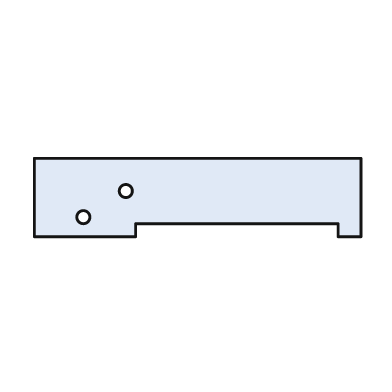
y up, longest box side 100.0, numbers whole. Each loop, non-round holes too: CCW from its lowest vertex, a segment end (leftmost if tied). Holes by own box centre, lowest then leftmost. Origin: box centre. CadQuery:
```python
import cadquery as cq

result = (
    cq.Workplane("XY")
    .moveTo(-50.0, -12.0)
    .lineTo(-19.0, -12.0)
    .lineTo(-19.0, -8.0)
    .lineTo(43.0, -8.0)
    .lineTo(43.0, -12.0)
    .lineTo(50.0, -12.0)
    .lineTo(50.0, 12.0)
    .lineTo(-50.0, 12.0)
    .close()
    .moveTo(-35.0, -6.0)
    .circle(2.0)
    .moveTo(-22.0, 2.0)
    .circle(2.0)
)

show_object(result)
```